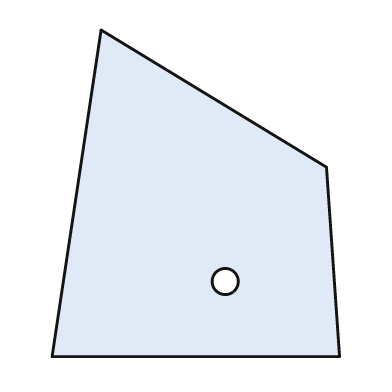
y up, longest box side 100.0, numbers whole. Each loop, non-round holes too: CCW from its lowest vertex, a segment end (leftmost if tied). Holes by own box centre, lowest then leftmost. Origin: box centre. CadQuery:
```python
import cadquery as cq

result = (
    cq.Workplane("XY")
    .moveTo(-44.0, -50.0)
    .lineTo(44.0, -50.0)
    .lineTo(40.0, 8.0)
    .lineTo(-29.0, 50.0)
    .close()
    .moveTo(9.0, -27.0)
    .circle(4.0)
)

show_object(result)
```